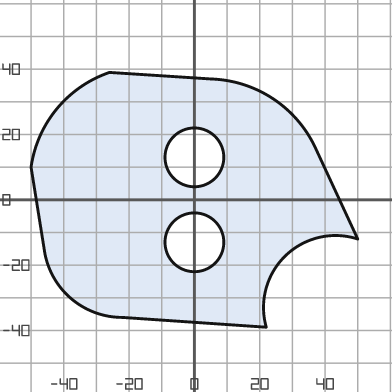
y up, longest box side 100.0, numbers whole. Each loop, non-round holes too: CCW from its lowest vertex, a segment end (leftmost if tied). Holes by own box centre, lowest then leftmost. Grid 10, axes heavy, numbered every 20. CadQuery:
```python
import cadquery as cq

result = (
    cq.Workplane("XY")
    .moveTo(22.0, -39.0)
    .threePointArc((28.0, -17.0), (50.0, -12.0))
    .lineTo(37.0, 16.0)
    .threePointArc((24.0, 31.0), (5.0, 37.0))
    .lineTo(-26.0, 39.0)
    .threePointArc((-42.0, 28.0), (-50.0, 10.0))
    .lineTo(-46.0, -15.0)
    .threePointArc((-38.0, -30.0), (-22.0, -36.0))
    .close()
    .moveTo(0.0, -13.0)
    .circle(9.0)
    .moveTo(0.0, 13.0)
    .circle(9.0)
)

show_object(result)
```